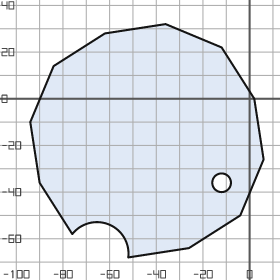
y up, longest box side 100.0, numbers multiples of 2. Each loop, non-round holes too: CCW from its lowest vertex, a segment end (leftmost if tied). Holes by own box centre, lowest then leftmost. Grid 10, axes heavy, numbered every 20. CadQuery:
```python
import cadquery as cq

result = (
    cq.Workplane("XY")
    .moveTo(-52.0, -68.0)
    .lineTo(-26.0, -64.0)
    .lineTo(-4.0, -50.0)
    .lineTo(6.0, -26.0)
    .lineTo(2.0, 0.0)
    .lineTo(-12.0, 22.0)
    .lineTo(-36.0, 32.0)
    .lineTo(-62.0, 28.0)
    .lineTo(-84.0, 14.0)
    .lineTo(-94.0, -10.0)
    .lineTo(-90.0, -36.0)
    .lineTo(-76.0, -58.0)
    .threePointArc((-60.0, -54.0), (-52.0, -68.0))
    .close()
    .moveTo(-12.0, -36.0)
    .circle(4.0)
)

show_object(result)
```